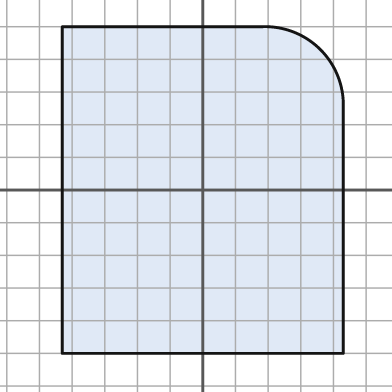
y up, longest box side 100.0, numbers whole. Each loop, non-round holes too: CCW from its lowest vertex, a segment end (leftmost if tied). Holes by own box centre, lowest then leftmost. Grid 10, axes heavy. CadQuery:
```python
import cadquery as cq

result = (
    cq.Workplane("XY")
    .moveTo(-43.0, -50.0)
    .lineTo(43.0, -50.0)
    .lineTo(43.0, 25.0)
    .threePointArc((36.0, 43.0), (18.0, 50.0))
    .lineTo(-43.0, 50.0)
    .close()
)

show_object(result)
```